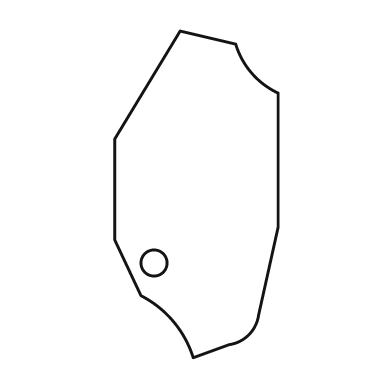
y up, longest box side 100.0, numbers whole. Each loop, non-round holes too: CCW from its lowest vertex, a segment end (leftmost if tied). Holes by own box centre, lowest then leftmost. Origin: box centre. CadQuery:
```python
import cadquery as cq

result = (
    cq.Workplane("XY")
    .moveTo(-1.0, -50.0)
    .lineTo(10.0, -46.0)
    .threePointArc((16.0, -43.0), (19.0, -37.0))
    .lineTo(25.0, -10.0)
    .lineTo(25.0, 31.0)
    .threePointArc((17.0, 37.0), (12.0, 46.0))
    .lineTo(-5.0, 50.0)
    .lineTo(-25.0, 17.0)
    .lineTo(-25.0, -14.0)
    .lineTo(-17.0, -31.0)
    .threePointArc((-7.0, -39.0), (-1.0, -50.0))
    .close()
    .moveTo(-13.0, -21.0)
    .circle(4.0)
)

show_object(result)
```